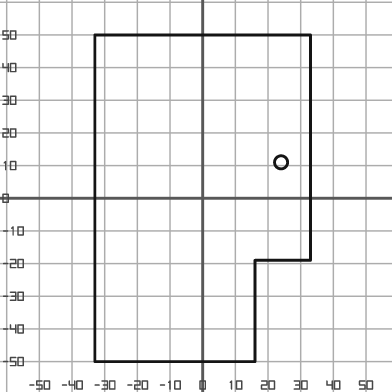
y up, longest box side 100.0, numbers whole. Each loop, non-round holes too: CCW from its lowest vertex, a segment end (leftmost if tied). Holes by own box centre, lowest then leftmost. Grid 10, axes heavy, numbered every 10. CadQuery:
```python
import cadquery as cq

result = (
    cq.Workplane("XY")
    .moveTo(-33.0, -50.0)
    .lineTo(16.0, -50.0)
    .lineTo(16.0, -19.0)
    .lineTo(33.0, -19.0)
    .lineTo(33.0, 50.0)
    .lineTo(-33.0, 50.0)
    .close()
    .moveTo(24.0, 11.0)
    .circle(2.0)
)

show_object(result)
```